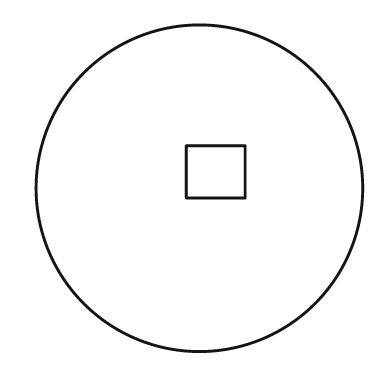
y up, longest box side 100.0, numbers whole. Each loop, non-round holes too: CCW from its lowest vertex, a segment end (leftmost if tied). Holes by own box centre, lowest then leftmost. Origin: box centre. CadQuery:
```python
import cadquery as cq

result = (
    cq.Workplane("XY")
    .moveTo(0.0, 0.0)
    .circle(50.0)
    .moveTo(-4.0, -3.0)
    .lineTo(14.0, -3.0)
    .lineTo(14.0, 13.0)
    .lineTo(-4.0, 13.0)
    .close()
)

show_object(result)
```